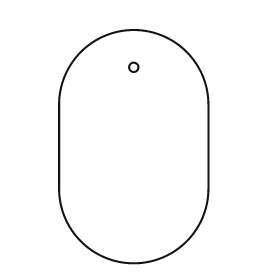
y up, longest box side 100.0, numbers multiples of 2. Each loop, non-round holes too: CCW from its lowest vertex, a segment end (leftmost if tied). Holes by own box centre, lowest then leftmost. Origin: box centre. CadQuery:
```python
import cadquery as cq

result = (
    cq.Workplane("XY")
    .moveTo(-32.0, -18.0)
    .threePointArc((0.0, -50.0), (32.0, -18.0))
    .lineTo(32.0, 18.0)
    .threePointArc((0.0, 50.0), (-32.0, 18.0))
    .close()
    .moveTo(0.0, 34.0)
    .circle(2.0)
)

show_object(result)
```